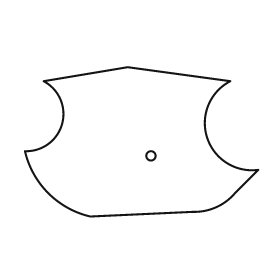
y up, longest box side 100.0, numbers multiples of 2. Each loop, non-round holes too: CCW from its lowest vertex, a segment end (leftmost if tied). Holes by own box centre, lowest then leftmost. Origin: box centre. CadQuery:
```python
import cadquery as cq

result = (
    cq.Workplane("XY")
    .moveTo(-22.0, -32.0)
    .lineTo(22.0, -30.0)
    .threePointArc((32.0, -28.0), (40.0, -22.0))
    .lineTo(50.0, -12.0)
    .threePointArc((28.0, 2.0), (38.0, 26.0))
    .lineTo(-6.0, 32.0)
    .lineTo(-42.0, 26.0)
    .threePointArc((-34.0, 8.0), (-50.0, -4.0))
    .threePointArc((-40.0, -22.0), (-22.0, -32.0))
    .close()
    .moveTo(4.0, -6.0)
    .circle(2.0)
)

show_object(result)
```